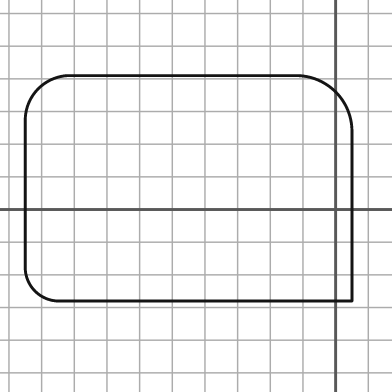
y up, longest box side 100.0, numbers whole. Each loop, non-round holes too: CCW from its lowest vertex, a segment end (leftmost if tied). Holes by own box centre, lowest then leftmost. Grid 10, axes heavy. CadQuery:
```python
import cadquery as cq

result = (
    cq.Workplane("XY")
    .moveTo(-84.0, -28.0)
    .lineTo(5.0, -28.0)
    .lineTo(5.0, 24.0)
    .threePointArc((0.0, 36.0), (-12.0, 41.0))
    .lineTo(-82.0, 41.0)
    .threePointArc((-91.0, 37.0), (-95.0, 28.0))
    .lineTo(-95.0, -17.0)
    .threePointArc((-92.0, -25.0), (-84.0, -28.0))
    .close()
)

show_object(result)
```